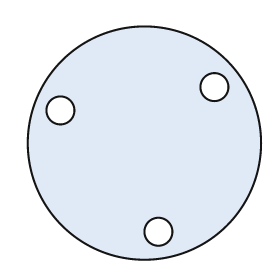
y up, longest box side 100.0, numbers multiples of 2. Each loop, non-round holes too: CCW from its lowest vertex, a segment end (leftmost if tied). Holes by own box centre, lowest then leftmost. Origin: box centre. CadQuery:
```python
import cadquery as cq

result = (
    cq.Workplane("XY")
    .moveTo(0.0, 0.0)
    .circle(50.0)
    .moveTo(6.0, -38.0)
    .circle(6.0)
    .moveTo(-36.0, 14.0)
    .circle(6.0)
    .moveTo(30.0, 24.0)
    .circle(6.0)
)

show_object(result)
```